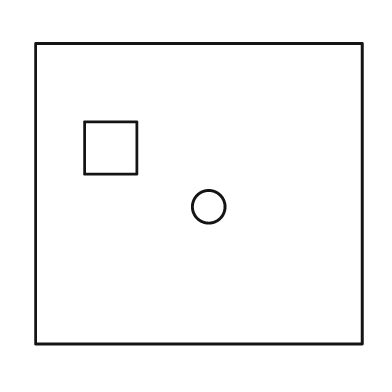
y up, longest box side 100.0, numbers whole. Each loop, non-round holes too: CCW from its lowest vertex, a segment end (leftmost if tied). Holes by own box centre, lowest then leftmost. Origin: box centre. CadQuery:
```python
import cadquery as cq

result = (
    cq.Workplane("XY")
    .moveTo(-50.0, -46.0)
    .lineTo(50.0, -46.0)
    .lineTo(50.0, 46.0)
    .lineTo(-50.0, 46.0)
    .close()
    .moveTo(3.0, -4.0)
    .circle(5.0)
    .moveTo(-35.0, 6.0)
    .lineTo(-19.0, 6.0)
    .lineTo(-19.0, 22.0)
    .lineTo(-35.0, 22.0)
    .close()
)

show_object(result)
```